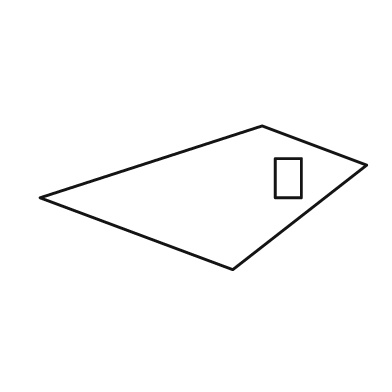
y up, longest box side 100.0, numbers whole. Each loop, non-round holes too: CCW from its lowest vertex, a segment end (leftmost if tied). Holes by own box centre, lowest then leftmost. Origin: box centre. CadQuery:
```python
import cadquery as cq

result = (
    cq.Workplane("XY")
    .moveTo(9.0, -22.0)
    .lineTo(50.0, 10.0)
    .lineTo(18.0, 22.0)
    .lineTo(-50.0, 0.0)
    .close()
    .moveTo(22.0, 0.0)
    .lineTo(30.0, 0.0)
    .lineTo(30.0, 12.0)
    .lineTo(22.0, 12.0)
    .close()
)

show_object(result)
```